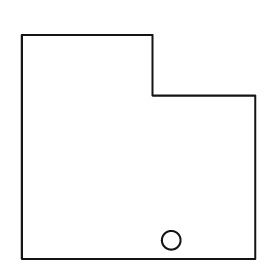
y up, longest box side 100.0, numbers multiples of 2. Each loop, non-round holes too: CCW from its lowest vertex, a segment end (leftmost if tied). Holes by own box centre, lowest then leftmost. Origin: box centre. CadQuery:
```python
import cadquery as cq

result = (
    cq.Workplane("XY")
    .moveTo(-50.0, -48.0)
    .lineTo(50.0, -48.0)
    .lineTo(50.0, 22.0)
    .lineTo(6.0, 22.0)
    .lineTo(6.0, 48.0)
    .lineTo(-50.0, 48.0)
    .close()
    .moveTo(14.0, -40.0)
    .circle(4.0)
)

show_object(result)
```